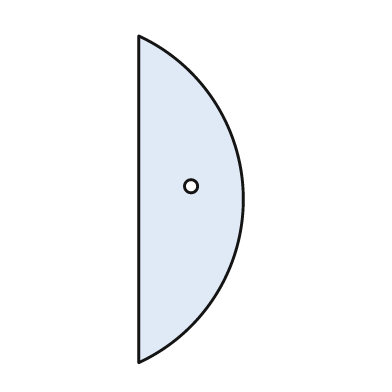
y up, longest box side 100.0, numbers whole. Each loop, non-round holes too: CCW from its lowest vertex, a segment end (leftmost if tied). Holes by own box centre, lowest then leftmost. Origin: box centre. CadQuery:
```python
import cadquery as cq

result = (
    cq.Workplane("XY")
    .moveTo(-16.0, -50.0)
    .threePointArc((16.0, 0.0), (-16.0, 50.0))
    .close()
    .moveTo(0.0, 4.0)
    .circle(2.0)
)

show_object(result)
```